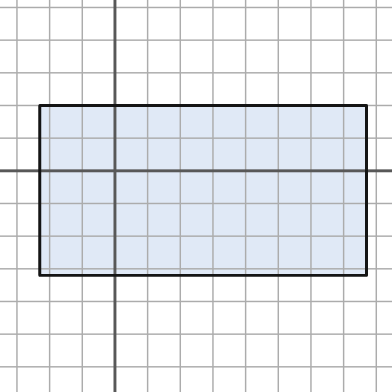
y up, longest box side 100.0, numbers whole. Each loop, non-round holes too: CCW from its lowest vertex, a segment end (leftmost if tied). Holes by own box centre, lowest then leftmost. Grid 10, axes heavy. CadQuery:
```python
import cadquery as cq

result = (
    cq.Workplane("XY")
    .moveTo(-23.0, -32.0)
    .lineTo(77.0, -32.0)
    .lineTo(77.0, 20.0)
    .lineTo(-23.0, 20.0)
    .close()
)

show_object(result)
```